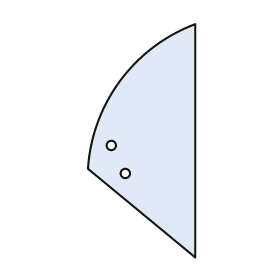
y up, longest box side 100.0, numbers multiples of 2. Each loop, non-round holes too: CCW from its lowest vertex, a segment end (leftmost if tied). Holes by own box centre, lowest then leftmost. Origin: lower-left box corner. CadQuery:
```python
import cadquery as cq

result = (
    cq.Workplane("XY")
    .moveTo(46.0, 0.0)
    .lineTo(46.0, 100.0)
    .threePointArc((14.0, 76.0), (0.0, 38.0))
    .close()
    .moveTo(16.0, 36.0)
    .circle(2.0)
    .moveTo(10.0, 48.0)
    .circle(2.0)
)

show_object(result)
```